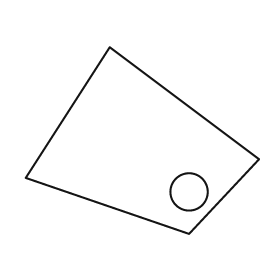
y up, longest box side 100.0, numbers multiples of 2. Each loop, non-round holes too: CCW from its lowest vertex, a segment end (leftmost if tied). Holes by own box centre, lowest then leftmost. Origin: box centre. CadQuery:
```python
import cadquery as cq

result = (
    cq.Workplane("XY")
    .moveTo(20.0, -40.0)
    .lineTo(50.0, -8.0)
    .lineTo(-14.0, 40.0)
    .lineTo(-50.0, -16.0)
    .close()
    .moveTo(20.0, -22.0)
    .circle(8.0)
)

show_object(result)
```